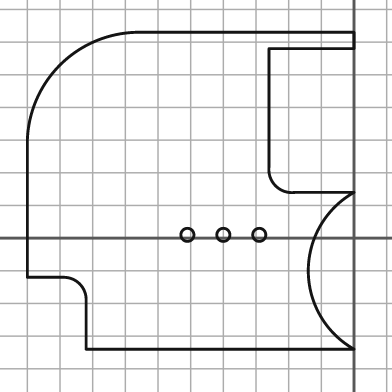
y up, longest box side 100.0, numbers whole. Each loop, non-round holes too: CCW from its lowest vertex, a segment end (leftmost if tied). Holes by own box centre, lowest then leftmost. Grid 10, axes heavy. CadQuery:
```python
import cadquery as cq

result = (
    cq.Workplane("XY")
    .moveTo(-82.0, -34.0)
    .lineTo(0.0, -34.0)
    .threePointArc((-14.0, -10.0), (0.0, 14.0))
    .lineTo(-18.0, 14.0)
    .threePointArc((-24.0, 16.0), (-26.0, 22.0))
    .lineTo(-26.0, 58.0)
    .lineTo(0.0, 58.0)
    .lineTo(0.0, 63.0)
    .lineTo(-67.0, 63.0)
    .threePointArc((-90.0, 53.0), (-100.0, 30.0))
    .lineTo(-100.0, -12.0)
    .lineTo(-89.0, -12.0)
    .threePointArc((-84.0, -14.0), (-82.0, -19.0))
    .close()
    .moveTo(-51.0, 1.0)
    .circle(2.0)
    .moveTo(-40.0, 1.0)
    .circle(2.0)
    .moveTo(-29.0, 1.0)
    .circle(2.0)
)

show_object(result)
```